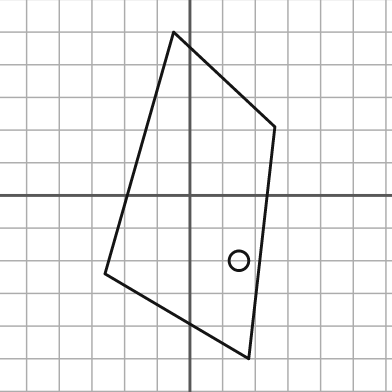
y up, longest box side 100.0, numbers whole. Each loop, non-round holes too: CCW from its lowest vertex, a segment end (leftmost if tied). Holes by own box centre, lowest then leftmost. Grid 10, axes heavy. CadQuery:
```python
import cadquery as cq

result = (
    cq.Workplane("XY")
    .moveTo(18.0, -50.0)
    .lineTo(26.0, 21.0)
    .lineTo(-5.0, 50.0)
    .lineTo(-26.0, -24.0)
    .close()
    .moveTo(15.0, -20.0)
    .circle(3.0)
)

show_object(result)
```